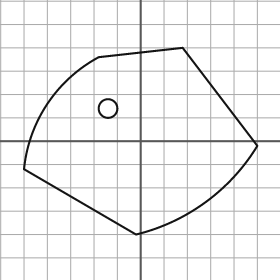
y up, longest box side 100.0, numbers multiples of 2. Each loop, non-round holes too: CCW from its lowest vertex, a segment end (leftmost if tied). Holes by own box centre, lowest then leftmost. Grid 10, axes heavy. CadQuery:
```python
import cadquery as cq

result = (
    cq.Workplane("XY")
    .moveTo(-2.0, -40.0)
    .threePointArc((28.0, -26.0), (50.0, -2.0))
    .lineTo(18.0, 40.0)
    .lineTo(-18.0, 36.0)
    .threePointArc((-40.0, 16.0), (-50.0, -12.0))
    .close()
    .moveTo(-14.0, 14.0)
    .circle(4.0)
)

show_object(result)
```